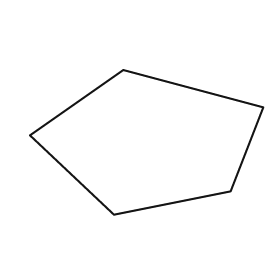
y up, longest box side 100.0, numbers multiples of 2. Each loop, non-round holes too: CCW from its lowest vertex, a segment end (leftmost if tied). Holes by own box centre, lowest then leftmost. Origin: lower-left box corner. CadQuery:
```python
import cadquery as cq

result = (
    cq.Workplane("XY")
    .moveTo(36.0, 0.0)
    .lineTo(86.0, 10.0)
    .lineTo(100.0, 46.0)
    .lineTo(40.0, 62.0)
    .lineTo(0.0, 34.0)
    .close()
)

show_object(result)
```